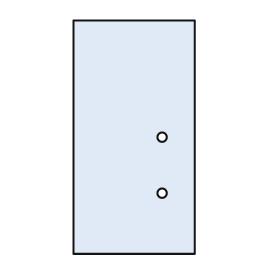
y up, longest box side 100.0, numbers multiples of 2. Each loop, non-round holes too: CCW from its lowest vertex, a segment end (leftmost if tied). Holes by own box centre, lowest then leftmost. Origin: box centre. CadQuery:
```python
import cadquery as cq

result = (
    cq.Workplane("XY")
    .moveTo(-26.0, -50.0)
    .lineTo(26.0, -50.0)
    .lineTo(26.0, 50.0)
    .lineTo(-26.0, 50.0)
    .close()
    .moveTo(12.0, -24.0)
    .circle(2.0)
    .moveTo(12.0, 0.0)
    .circle(2.0)
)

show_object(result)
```